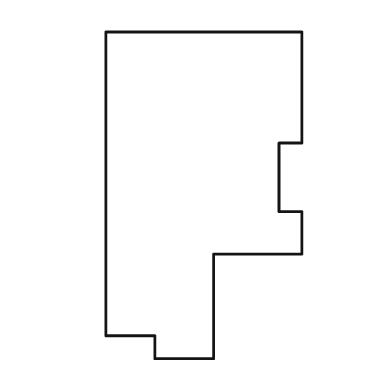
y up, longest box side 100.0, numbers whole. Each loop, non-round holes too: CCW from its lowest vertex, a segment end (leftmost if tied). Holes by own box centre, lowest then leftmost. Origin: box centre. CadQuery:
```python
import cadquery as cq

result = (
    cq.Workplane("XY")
    .moveTo(-15.0, -50.0)
    .lineTo(3.0, -50.0)
    .lineTo(3.0, -18.0)
    .lineTo(30.0, -18.0)
    .lineTo(30.0, -5.0)
    .lineTo(23.0, -5.0)
    .lineTo(23.0, 16.0)
    .lineTo(30.0, 16.0)
    .lineTo(30.0, 50.0)
    .lineTo(-30.0, 50.0)
    .lineTo(-30.0, -43.0)
    .lineTo(-15.0, -43.0)
    .close()
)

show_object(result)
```